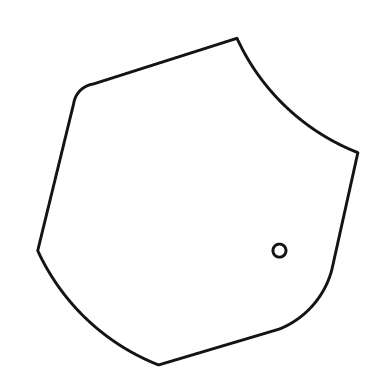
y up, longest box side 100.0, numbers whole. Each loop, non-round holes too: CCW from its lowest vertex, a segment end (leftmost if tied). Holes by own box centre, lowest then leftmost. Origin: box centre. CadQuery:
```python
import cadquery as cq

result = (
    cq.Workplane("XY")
    .moveTo(-12.0, -50.0)
    .lineTo(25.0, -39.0)
    .threePointArc((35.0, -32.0), (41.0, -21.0))
    .lineTo(49.0, 15.0)
    .threePointArc((27.0, 29.0), (12.0, 50.0))
    .lineTo(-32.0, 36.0)
    .threePointArc((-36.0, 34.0), (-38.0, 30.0))
    .lineTo(-49.0, -15.0)
    .threePointArc((-34.0, -36.0), (-12.0, -50.0))
    .close()
    .moveTo(25.0, -15.0)
    .circle(2.0)
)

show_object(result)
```